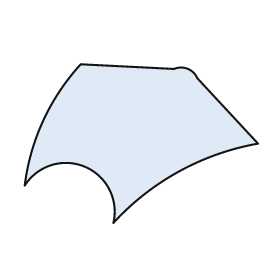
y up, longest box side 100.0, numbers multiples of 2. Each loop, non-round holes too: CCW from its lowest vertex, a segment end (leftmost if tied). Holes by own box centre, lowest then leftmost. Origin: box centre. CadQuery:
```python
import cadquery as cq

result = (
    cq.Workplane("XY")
    .moveTo(-12.0, -34.0)
    .threePointArc((16.0, -12.0), (50.0, 0.0))
    .lineTo(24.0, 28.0)
    .threePointArc((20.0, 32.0), (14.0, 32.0))
    .lineTo(-26.0, 34.0)
    .threePointArc((-42.0, 10.0), (-50.0, -18.0))
    .threePointArc((-24.0, -10.0), (-12.0, -34.0))
    .close()
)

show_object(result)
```